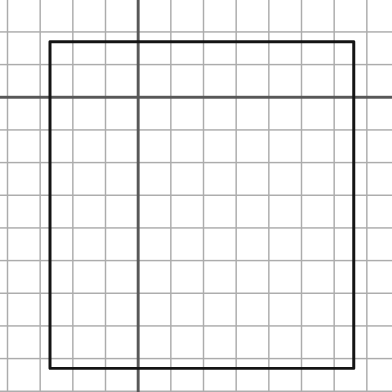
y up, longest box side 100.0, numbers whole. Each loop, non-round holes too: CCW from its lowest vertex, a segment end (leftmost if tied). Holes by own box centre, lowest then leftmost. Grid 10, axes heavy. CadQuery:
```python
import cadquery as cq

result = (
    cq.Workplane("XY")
    .moveTo(-27.0, -83.0)
    .lineTo(66.0, -83.0)
    .lineTo(66.0, 17.0)
    .lineTo(-27.0, 17.0)
    .close()
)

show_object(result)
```